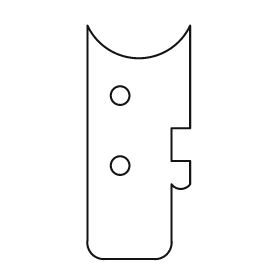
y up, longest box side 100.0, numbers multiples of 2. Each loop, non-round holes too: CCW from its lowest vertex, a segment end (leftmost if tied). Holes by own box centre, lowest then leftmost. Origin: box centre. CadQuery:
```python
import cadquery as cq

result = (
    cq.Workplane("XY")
    .moveTo(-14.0, -50.0)
    .lineTo(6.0, -50.0)
    .threePointArc((12.0, -48.0), (14.0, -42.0))
    .lineTo(14.0, -18.0)
    .threePointArc((18.0, -20.0), (22.0, -18.0))
    .lineTo(22.0, -8.0)
    .lineTo(14.0, -8.0)
    .lineTo(14.0, 6.0)
    .lineTo(22.0, 6.0)
    .lineTo(22.0, 50.0)
    .threePointArc((0.0, 36.0), (-22.0, 50.0))
    .lineTo(-22.0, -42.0)
    .threePointArc((-20.0, -48.0), (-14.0, -50.0))
    .close()
    .moveTo(-8.0, -10.0)
    .circle(4.0)
    .moveTo(-8.0, 20.0)
    .circle(4.0)
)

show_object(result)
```